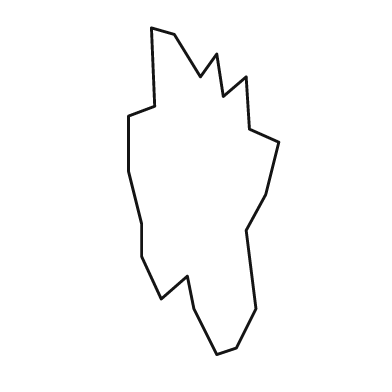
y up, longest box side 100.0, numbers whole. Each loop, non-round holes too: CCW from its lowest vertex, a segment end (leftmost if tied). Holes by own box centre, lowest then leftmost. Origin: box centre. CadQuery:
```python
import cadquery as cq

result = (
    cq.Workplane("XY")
    .moveTo(4.0, -50.0)
    .lineTo(10.0, -48.0)
    .lineTo(16.0, -36.0)
    .lineTo(13.0, -12.0)
    .lineTo(19.0, -1.0)
    .lineTo(23.0, 15.0)
    .lineTo(14.0, 19.0)
    .lineTo(13.0, 35.0)
    .lineTo(6.0, 29.0)
    .lineTo(4.0, 42.0)
    .lineTo(-1.0, 35.0)
    .lineTo(-9.0, 48.0)
    .lineTo(-16.0, 50.0)
    .lineTo(-15.0, 26.0)
    .lineTo(-23.0, 23.0)
    .lineTo(-23.0, 6.0)
    .lineTo(-19.0, -10.0)
    .lineTo(-19.0, -20.0)
    .lineTo(-13.0, -33.0)
    .lineTo(-5.0, -26.0)
    .lineTo(-3.0, -36.0)
    .close()
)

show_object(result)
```